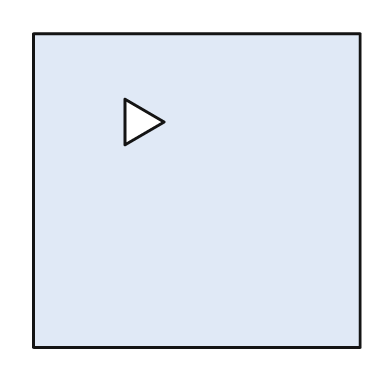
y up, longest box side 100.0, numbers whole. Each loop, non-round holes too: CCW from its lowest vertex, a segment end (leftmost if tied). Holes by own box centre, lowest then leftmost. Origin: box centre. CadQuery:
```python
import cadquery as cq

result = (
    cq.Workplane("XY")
    .moveTo(-50.0, -48.0)
    .lineTo(50.0, -48.0)
    .lineTo(50.0, 48.0)
    .lineTo(-50.0, 48.0)
    .close()
    .moveTo(-22.0, 14.0)
    .lineTo(-10.0, 21.0)
    .lineTo(-22.0, 28.0)
    .close()
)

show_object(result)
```